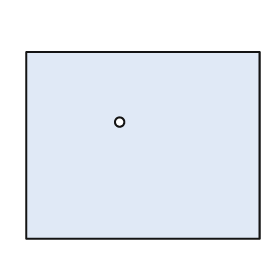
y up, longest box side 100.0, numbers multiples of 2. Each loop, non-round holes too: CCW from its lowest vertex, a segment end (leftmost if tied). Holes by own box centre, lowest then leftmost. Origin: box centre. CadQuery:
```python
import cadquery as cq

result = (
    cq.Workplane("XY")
    .moveTo(-50.0, -40.0)
    .lineTo(50.0, -40.0)
    .lineTo(50.0, 40.0)
    .lineTo(-50.0, 40.0)
    .close()
    .moveTo(-10.0, 10.0)
    .circle(2.0)
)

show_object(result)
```